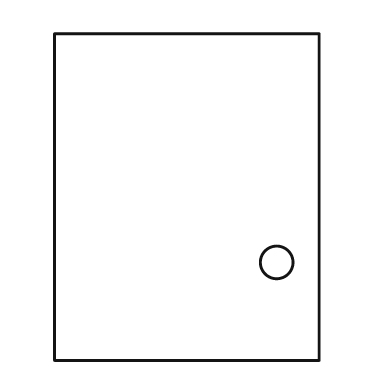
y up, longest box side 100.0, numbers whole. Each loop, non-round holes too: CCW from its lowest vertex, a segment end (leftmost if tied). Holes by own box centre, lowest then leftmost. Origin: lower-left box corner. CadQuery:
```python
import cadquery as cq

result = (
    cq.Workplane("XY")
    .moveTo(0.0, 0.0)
    .lineTo(81.0, 0.0)
    .lineTo(81.0, 100.0)
    .lineTo(0.0, 100.0)
    .close()
    .moveTo(68.0, 30.0)
    .circle(5.0)
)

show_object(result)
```